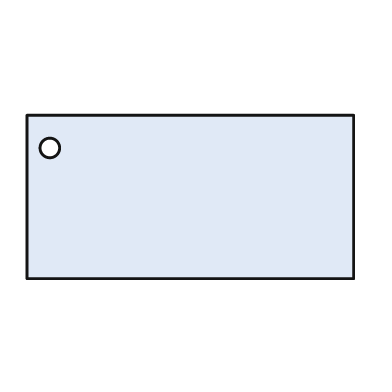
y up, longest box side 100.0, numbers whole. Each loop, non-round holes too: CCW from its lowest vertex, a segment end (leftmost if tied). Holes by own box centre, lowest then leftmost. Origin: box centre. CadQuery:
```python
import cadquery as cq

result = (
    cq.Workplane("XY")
    .moveTo(-50.0, -25.0)
    .lineTo(50.0, -25.0)
    .lineTo(50.0, 25.0)
    .lineTo(-50.0, 25.0)
    .close()
    .moveTo(-43.0, 15.0)
    .circle(3.0)
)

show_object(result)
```